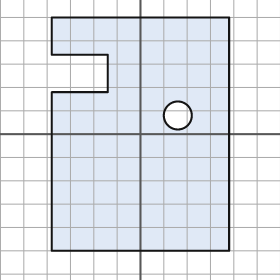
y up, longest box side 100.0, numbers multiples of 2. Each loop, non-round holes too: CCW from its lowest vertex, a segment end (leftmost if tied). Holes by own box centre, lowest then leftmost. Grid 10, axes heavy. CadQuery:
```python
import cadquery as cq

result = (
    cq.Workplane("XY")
    .moveTo(-38.0, -50.0)
    .lineTo(38.0, -50.0)
    .lineTo(38.0, 50.0)
    .lineTo(-38.0, 50.0)
    .lineTo(-38.0, 34.0)
    .lineTo(-14.0, 34.0)
    .lineTo(-14.0, 18.0)
    .lineTo(-38.0, 18.0)
    .close()
    .moveTo(16.0, 8.0)
    .circle(6.0)
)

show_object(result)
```